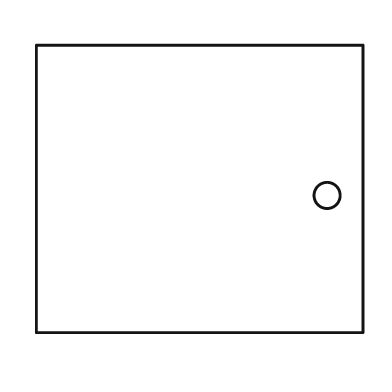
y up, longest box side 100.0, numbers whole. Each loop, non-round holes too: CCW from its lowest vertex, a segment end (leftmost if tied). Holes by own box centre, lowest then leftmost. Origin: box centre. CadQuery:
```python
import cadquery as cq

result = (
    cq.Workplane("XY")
    .moveTo(-50.0, -44.0)
    .lineTo(50.0, -44.0)
    .lineTo(50.0, 44.0)
    .lineTo(-50.0, 44.0)
    .close()
    .moveTo(39.0, -2.0)
    .circle(4.0)
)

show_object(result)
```